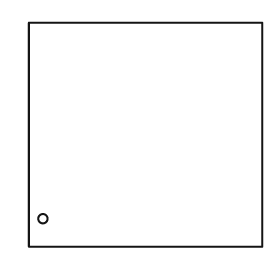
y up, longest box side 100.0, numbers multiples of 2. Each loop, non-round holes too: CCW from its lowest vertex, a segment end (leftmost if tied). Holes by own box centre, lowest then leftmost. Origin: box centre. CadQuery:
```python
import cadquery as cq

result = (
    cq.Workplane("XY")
    .moveTo(-50.0, -48.0)
    .lineTo(50.0, -48.0)
    .lineTo(50.0, 48.0)
    .lineTo(-50.0, 48.0)
    .close()
    .moveTo(-44.0, -36.0)
    .circle(2.0)
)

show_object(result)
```